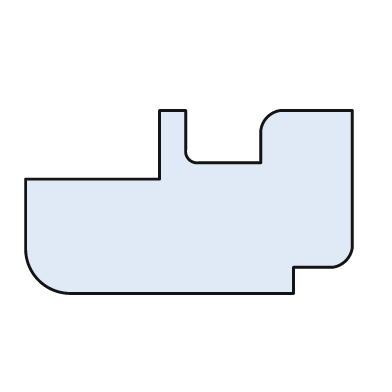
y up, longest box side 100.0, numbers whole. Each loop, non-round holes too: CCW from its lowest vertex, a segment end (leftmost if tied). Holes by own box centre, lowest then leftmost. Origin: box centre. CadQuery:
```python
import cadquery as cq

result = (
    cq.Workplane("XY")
    .moveTo(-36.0, -28.0)
    .lineTo(32.0, -28.0)
    .lineTo(32.0, -20.0)
    .lineTo(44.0, -20.0)
    .threePointArc((48.0, -18.0), (50.0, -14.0))
    .lineTo(50.0, 28.0)
    .lineTo(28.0, 28.0)
    .threePointArc((24.0, 26.0), (22.0, 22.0))
    .lineTo(22.0, 12.0)
    .lineTo(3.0, 12.0)
    .threePointArc((0.0, 13.0), (-1.0, 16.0))
    .lineTo(-1.0, 28.0)
    .lineTo(-9.0, 28.0)
    .lineTo(-9.0, 7.0)
    .lineTo(-50.0, 7.0)
    .lineTo(-50.0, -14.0)
    .threePointArc((-46.0, -24.0), (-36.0, -28.0))
    .close()
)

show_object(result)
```